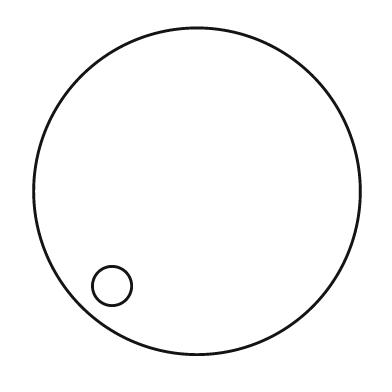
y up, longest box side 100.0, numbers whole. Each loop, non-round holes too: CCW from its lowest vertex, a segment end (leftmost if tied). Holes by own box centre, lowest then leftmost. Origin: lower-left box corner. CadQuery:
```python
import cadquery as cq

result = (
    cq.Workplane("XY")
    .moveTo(50.0, 50.0)
    .circle(50.0)
    .moveTo(24.0, 21.0)
    .circle(6.0)
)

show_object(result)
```